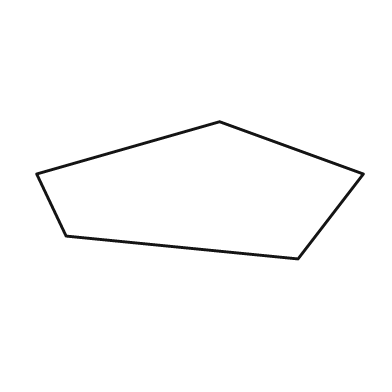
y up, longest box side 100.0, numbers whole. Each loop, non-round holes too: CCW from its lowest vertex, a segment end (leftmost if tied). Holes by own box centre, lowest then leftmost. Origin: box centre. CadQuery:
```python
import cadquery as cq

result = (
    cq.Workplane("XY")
    .moveTo(30.0, -21.0)
    .lineTo(50.0, 5.0)
    .lineTo(6.0, 21.0)
    .lineTo(-50.0, 5.0)
    .lineTo(-41.0, -14.0)
    .close()
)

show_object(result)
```